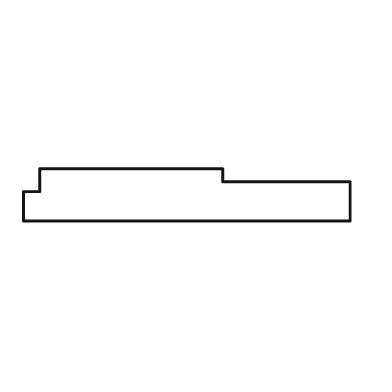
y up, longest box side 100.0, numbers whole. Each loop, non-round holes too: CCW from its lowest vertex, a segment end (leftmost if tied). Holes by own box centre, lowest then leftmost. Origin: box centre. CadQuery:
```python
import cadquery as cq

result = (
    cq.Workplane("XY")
    .moveTo(-50.0, -8.0)
    .lineTo(50.0, -8.0)
    .lineTo(50.0, 4.0)
    .lineTo(11.0, 4.0)
    .lineTo(11.0, 8.0)
    .lineTo(-45.0, 8.0)
    .lineTo(-45.0, 1.0)
    .lineTo(-50.0, 1.0)
    .close()
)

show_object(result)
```